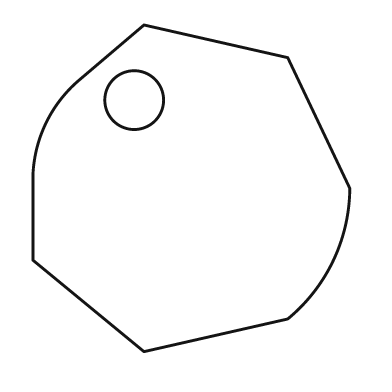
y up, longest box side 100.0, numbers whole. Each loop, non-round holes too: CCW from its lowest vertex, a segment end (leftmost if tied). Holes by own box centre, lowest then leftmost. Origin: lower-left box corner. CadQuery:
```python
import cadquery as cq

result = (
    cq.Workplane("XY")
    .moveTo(34.0, 0.0)
    .lineTo(78.0, 10.0)
    .threePointArc((92.0, 28.0), (97.0, 50.0))
    .lineTo(78.0, 90.0)
    .lineTo(34.0, 100.0)
    .lineTo(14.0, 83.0)
    .threePointArc((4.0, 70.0), (0.0, 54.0))
    .lineTo(0.0, 28.0)
    .close()
    .moveTo(31.0, 77.0)
    .circle(9.0)
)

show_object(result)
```